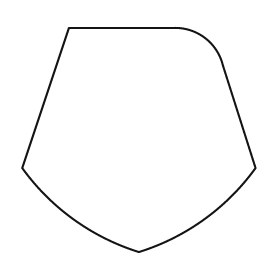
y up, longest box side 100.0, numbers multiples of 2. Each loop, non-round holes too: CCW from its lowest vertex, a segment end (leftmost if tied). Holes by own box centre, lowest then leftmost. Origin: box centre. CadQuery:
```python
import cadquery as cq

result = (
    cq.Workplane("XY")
    .moveTo(0.0, -48.0)
    .threePointArc((28.0, -34.0), (50.0, -12.0))
    .lineTo(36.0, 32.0)
    .threePointArc((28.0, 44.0), (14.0, 48.0))
    .lineTo(-30.0, 48.0)
    .lineTo(-50.0, -12.0)
    .threePointArc((-28.0, -34.0), (0.0, -48.0))
    .close()
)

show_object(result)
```